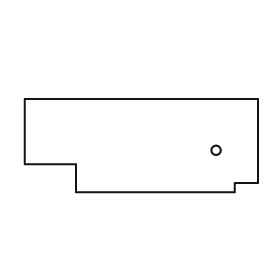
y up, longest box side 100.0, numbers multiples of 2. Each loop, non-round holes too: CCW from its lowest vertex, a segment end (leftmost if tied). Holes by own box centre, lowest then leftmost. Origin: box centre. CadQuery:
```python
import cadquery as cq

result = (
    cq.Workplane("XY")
    .moveTo(-28.0, -20.0)
    .lineTo(40.0, -20.0)
    .lineTo(40.0, -16.0)
    .lineTo(50.0, -16.0)
    .lineTo(50.0, 20.0)
    .lineTo(-50.0, 20.0)
    .lineTo(-50.0, -8.0)
    .lineTo(-28.0, -8.0)
    .close()
    .moveTo(32.0, -2.0)
    .circle(2.0)
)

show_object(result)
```